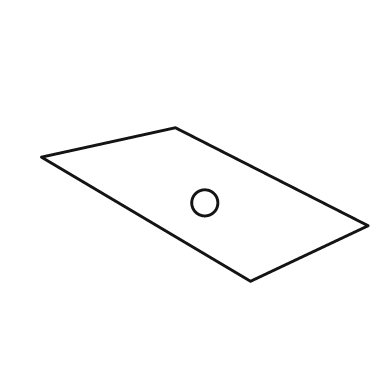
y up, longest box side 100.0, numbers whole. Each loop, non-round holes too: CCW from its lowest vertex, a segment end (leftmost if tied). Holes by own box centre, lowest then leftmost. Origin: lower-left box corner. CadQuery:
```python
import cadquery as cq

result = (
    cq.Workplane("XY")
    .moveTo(64.0, 0.0)
    .lineTo(100.0, 17.0)
    .lineTo(41.0, 47.0)
    .lineTo(0.0, 38.0)
    .close()
    .moveTo(50.0, 24.0)
    .circle(4.0)
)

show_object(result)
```